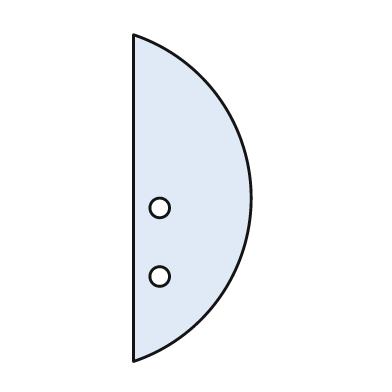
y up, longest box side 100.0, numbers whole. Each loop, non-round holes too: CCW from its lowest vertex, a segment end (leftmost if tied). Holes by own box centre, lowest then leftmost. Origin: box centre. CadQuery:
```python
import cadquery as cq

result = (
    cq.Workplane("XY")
    .moveTo(-18.0, -50.0)
    .threePointArc((18.0, 0.0), (-18.0, 50.0))
    .close()
    .moveTo(-10.0, -24.0)
    .circle(3.0)
    .moveTo(-10.0, -3.0)
    .circle(3.0)
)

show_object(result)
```